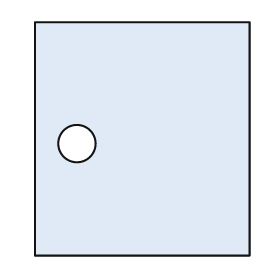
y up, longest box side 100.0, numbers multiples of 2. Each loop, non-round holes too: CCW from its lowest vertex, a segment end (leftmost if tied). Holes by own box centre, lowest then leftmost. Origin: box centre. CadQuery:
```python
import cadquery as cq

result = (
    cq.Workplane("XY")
    .moveTo(-46.0, -50.0)
    .lineTo(46.0, -50.0)
    .lineTo(46.0, 50.0)
    .lineTo(-46.0, 50.0)
    .close()
    .moveTo(-28.0, -2.0)
    .circle(8.0)
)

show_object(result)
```